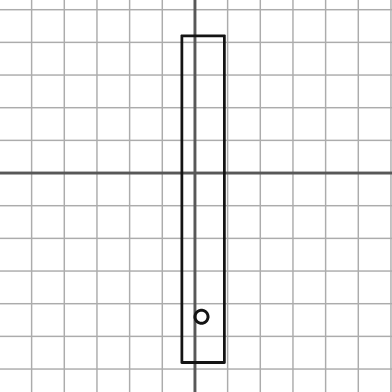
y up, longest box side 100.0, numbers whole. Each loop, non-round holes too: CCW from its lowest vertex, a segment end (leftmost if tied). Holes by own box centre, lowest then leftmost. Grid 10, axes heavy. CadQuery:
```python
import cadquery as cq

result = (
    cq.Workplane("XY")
    .moveTo(-4.0, -58.0)
    .lineTo(9.0, -58.0)
    .lineTo(9.0, 42.0)
    .lineTo(-4.0, 42.0)
    .close()
    .moveTo(2.0, -44.0)
    .circle(2.0)
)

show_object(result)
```